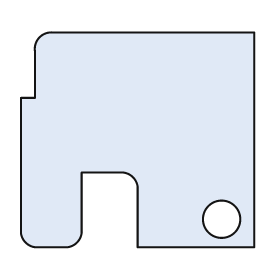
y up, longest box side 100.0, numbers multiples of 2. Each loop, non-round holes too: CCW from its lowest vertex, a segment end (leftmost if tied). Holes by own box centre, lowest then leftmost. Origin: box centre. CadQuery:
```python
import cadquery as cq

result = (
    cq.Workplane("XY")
    .moveTo(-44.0, -46.0)
    .lineTo(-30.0, -46.0)
    .threePointArc((-26.0, -44.0), (-24.0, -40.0))
    .lineTo(-24.0, -14.0)
    .lineTo(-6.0, -14.0)
    .threePointArc((-2.0, -16.0), (0.0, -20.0))
    .lineTo(0.0, -46.0)
    .lineTo(50.0, -46.0)
    .lineTo(50.0, 46.0)
    .lineTo(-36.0, 46.0)
    .threePointArc((-42.0, 44.0), (-44.0, 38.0))
    .lineTo(-44.0, 18.0)
    .lineTo(-50.0, 18.0)
    .lineTo(-50.0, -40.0)
    .threePointArc((-48.0, -44.0), (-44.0, -46.0))
    .close()
    .moveTo(36.0, -34.0)
    .circle(8.0)
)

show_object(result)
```